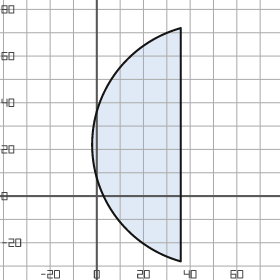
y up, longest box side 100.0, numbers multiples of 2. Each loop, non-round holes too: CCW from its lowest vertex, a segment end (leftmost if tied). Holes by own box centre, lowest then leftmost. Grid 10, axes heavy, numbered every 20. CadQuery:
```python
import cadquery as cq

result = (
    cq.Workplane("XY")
    .moveTo(36.0, -28.0)
    .lineTo(36.0, 72.0)
    .threePointArc((-2.0, 22.0), (36.0, -28.0))
    .close()
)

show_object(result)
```